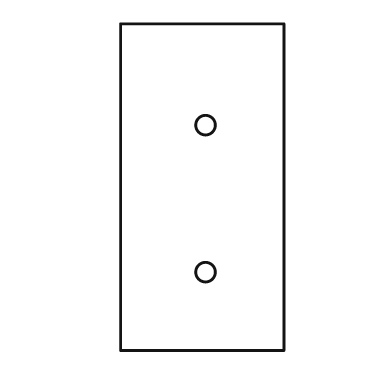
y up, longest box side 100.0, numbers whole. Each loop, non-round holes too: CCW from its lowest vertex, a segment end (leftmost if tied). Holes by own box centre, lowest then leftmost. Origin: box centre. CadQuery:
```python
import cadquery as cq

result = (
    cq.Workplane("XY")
    .moveTo(-25.0, -50.0)
    .lineTo(25.0, -50.0)
    .lineTo(25.0, 50.0)
    .lineTo(-25.0, 50.0)
    .close()
    .moveTo(1.0, -26.0)
    .circle(3.0)
    .moveTo(1.0, 19.0)
    .circle(3.0)
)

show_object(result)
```